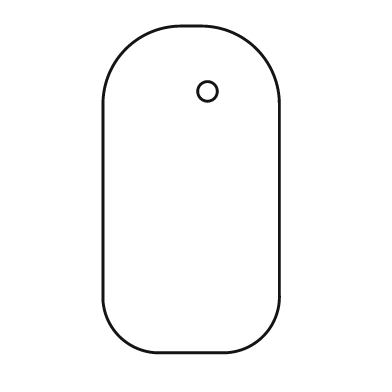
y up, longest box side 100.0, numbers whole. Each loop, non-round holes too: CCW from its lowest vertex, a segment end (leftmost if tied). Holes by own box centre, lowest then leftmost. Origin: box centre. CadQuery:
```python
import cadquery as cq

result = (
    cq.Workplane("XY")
    .moveTo(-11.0, -50.0)
    .lineTo(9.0, -50.0)
    .threePointArc((22.0, -45.0), (27.0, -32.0))
    .lineTo(27.0, 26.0)
    .threePointArc((20.0, 43.0), (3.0, 50.0))
    .lineTo(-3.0, 50.0)
    .threePointArc((-20.0, 43.0), (-27.0, 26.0))
    .lineTo(-27.0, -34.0)
    .threePointArc((-22.0, -45.0), (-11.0, -50.0))
    .close()
    .moveTo(5.0, 30.0)
    .circle(3.0)
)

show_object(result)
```